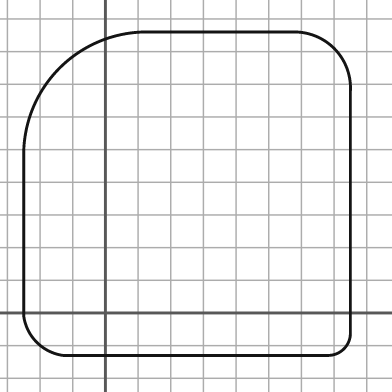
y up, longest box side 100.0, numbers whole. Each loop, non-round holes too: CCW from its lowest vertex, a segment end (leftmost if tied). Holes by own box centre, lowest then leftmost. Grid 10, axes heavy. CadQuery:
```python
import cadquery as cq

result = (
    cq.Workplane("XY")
    .moveTo(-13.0, -13.0)
    .lineTo(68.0, -13.0)
    .threePointArc((73.0, -11.0), (75.0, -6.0))
    .lineTo(75.0, 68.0)
    .threePointArc((70.0, 81.0), (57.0, 86.0))
    .lineTo(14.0, 86.0)
    .threePointArc((-14.0, 75.0), (-25.0, 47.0))
    .lineTo(-25.0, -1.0)
    .threePointArc((-21.0, -9.0), (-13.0, -13.0))
    .close()
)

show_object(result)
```